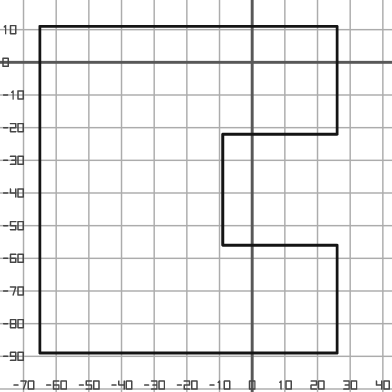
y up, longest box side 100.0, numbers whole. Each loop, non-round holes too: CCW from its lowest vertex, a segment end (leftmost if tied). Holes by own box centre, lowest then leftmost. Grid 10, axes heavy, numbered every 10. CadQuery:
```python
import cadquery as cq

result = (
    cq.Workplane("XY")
    .moveTo(-65.0, -89.0)
    .lineTo(26.0, -89.0)
    .lineTo(26.0, -56.0)
    .lineTo(-9.0, -56.0)
    .lineTo(-9.0, -22.0)
    .lineTo(26.0, -22.0)
    .lineTo(26.0, 11.0)
    .lineTo(-65.0, 11.0)
    .close()
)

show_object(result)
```